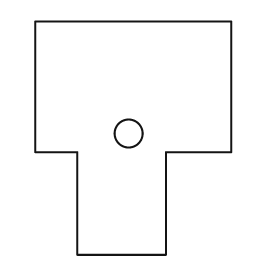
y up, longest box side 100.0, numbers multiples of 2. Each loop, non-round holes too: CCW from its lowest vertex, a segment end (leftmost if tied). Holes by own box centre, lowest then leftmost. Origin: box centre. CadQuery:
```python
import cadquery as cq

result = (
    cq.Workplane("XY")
    .moveTo(-24.0, -50.0)
    .lineTo(14.0, -50.0)
    .lineTo(14.0, -6.0)
    .lineTo(42.0, -6.0)
    .lineTo(42.0, 50.0)
    .lineTo(-42.0, 50.0)
    .lineTo(-42.0, -6.0)
    .lineTo(-24.0, -6.0)
    .close()
    .moveTo(-2.0, 2.0)
    .circle(6.0)
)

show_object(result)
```